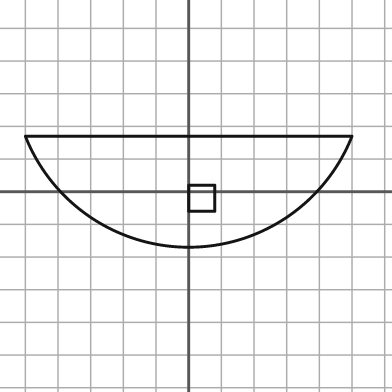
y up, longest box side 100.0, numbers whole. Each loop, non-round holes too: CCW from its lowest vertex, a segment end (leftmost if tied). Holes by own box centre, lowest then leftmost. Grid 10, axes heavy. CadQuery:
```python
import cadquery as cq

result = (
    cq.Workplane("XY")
    .moveTo(-50.0, 17.0)
    .threePointArc((0.0, -17.0), (50.0, 17.0))
    .close()
    .moveTo(0.0, -6.0)
    .lineTo(8.0, -6.0)
    .lineTo(8.0, 2.0)
    .lineTo(0.0, 2.0)
    .close()
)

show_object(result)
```